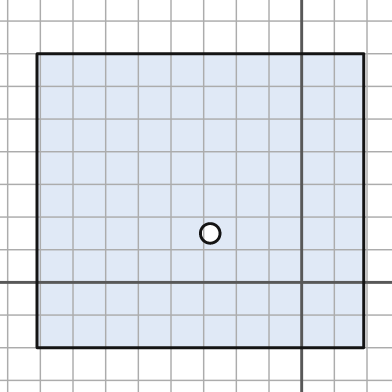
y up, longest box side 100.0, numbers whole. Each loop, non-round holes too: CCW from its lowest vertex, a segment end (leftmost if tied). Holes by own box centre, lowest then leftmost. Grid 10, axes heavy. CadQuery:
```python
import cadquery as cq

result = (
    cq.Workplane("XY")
    .moveTo(-81.0, -20.0)
    .lineTo(19.0, -20.0)
    .lineTo(19.0, 70.0)
    .lineTo(-81.0, 70.0)
    .close()
    .moveTo(-28.0, 15.0)
    .circle(3.0)
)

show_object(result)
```